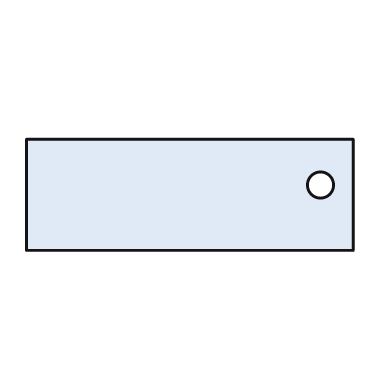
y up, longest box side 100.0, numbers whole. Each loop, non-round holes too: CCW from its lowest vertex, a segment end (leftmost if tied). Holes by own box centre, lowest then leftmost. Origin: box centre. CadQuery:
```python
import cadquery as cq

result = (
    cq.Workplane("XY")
    .moveTo(-50.0, -17.0)
    .lineTo(50.0, -17.0)
    .lineTo(50.0, 17.0)
    .lineTo(-50.0, 17.0)
    .close()
    .moveTo(40.0, 3.0)
    .circle(4.0)
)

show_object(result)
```